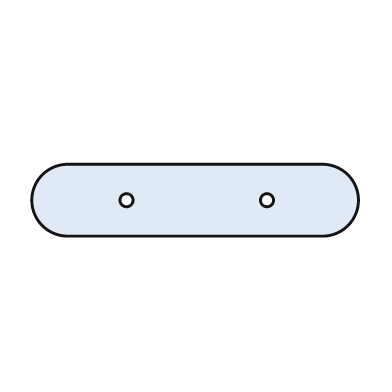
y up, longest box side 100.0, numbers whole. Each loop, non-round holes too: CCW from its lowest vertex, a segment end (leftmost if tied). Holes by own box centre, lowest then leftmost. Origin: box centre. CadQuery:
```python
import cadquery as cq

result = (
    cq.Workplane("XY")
    .moveTo(-39.0, -11.0)
    .lineTo(39.0, -11.0)
    .threePointArc((50.0, 0.0), (39.0, 11.0))
    .lineTo(-39.0, 11.0)
    .threePointArc((-50.0, 0.0), (-39.0, -11.0))
    .close()
    .moveTo(-21.0, 0.0)
    .circle(2.0)
    .moveTo(22.0, 0.0)
    .circle(2.0)
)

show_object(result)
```